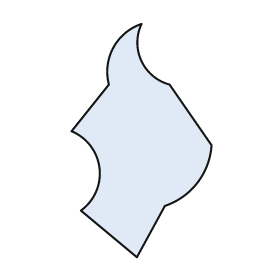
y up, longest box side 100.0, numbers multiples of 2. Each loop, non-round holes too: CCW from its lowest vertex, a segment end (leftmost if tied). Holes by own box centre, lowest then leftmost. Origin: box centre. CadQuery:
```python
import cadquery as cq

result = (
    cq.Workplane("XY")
    .moveTo(-2.0, -50.0)
    .lineTo(10.0, -28.0)
    .threePointArc((24.0, -18.0), (30.0, -2.0))
    .lineTo(12.0, 24.0)
    .threePointArc((0.0, 34.0), (0.0, 50.0))
    .threePointArc((-12.0, 40.0), (-14.0, 24.0))
    .lineTo(-30.0, 4.0)
    .threePointArc((-18.0, -12.0), (-26.0, -30.0))
    .close()
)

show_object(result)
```